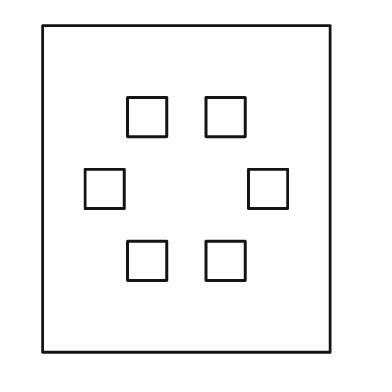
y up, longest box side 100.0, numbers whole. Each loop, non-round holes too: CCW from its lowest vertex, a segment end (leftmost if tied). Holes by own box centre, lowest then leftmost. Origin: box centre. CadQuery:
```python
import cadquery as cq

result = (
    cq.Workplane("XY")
    .moveTo(-44.0, -50.0)
    .lineTo(44.0, -50.0)
    .lineTo(44.0, 50.0)
    .lineTo(-44.0, 50.0)
    .close()
    .moveTo(-18.0, -28.0)
    .lineTo(-6.0, -28.0)
    .lineTo(-6.0, -16.0)
    .lineTo(-18.0, -16.0)
    .close()
    .moveTo(6.0, -28.0)
    .lineTo(18.0, -28.0)
    .lineTo(18.0, -16.0)
    .lineTo(6.0, -16.0)
    .close()
    .moveTo(-31.0, -6.0)
    .lineTo(-19.0, -6.0)
    .lineTo(-19.0, 6.0)
    .lineTo(-31.0, 6.0)
    .close()
    .moveTo(19.0, -6.0)
    .lineTo(31.0, -6.0)
    .lineTo(31.0, 6.0)
    .lineTo(19.0, 6.0)
    .close()
    .moveTo(-18.0, 16.0)
    .lineTo(-6.0, 16.0)
    .lineTo(-6.0, 28.0)
    .lineTo(-18.0, 28.0)
    .close()
    .moveTo(6.0, 16.0)
    .lineTo(18.0, 16.0)
    .lineTo(18.0, 28.0)
    .lineTo(6.0, 28.0)
    .close()
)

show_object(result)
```